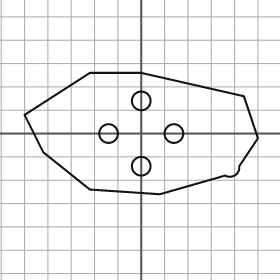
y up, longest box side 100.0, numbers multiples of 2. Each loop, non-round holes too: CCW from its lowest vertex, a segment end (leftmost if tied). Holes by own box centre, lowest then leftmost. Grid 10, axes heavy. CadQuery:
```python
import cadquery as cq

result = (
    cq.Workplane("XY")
    .moveTo(8.0, -26.0)
    .lineTo(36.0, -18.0)
    .threePointArc((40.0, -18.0), (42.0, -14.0))
    .lineTo(50.0, -2.0)
    .lineTo(44.0, 16.0)
    .lineTo(0.0, 26.0)
    .lineTo(-22.0, 26.0)
    .lineTo(-50.0, 8.0)
    .lineTo(-42.0, -8.0)
    .lineTo(-22.0, -24.0)
    .close()
    .moveTo(0.0, -14.0)
    .circle(4.0)
    .moveTo(-14.0, 0.0)
    .circle(4.0)
    .moveTo(14.0, 0.0)
    .circle(4.0)
    .moveTo(0.0, 14.0)
    .circle(4.0)
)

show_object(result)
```